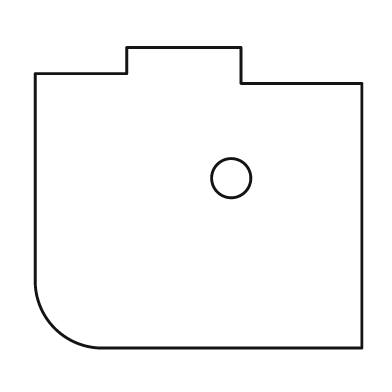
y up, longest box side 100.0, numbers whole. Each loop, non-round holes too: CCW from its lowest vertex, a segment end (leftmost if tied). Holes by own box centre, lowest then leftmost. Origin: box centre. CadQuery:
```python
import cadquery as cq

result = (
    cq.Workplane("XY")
    .moveTo(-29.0, -46.0)
    .lineTo(50.0, -46.0)
    .lineTo(50.0, 35.0)
    .lineTo(13.0, 35.0)
    .lineTo(13.0, 46.0)
    .lineTo(-22.0, 46.0)
    .lineTo(-22.0, 38.0)
    .lineTo(-50.0, 38.0)
    .lineTo(-50.0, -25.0)
    .threePointArc((-44.0, -40.0), (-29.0, -46.0))
    .close()
    .moveTo(10.0, 6.0)
    .circle(6.0)
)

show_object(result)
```